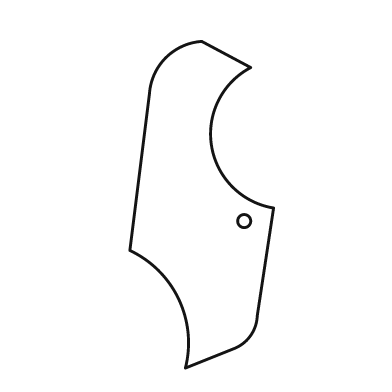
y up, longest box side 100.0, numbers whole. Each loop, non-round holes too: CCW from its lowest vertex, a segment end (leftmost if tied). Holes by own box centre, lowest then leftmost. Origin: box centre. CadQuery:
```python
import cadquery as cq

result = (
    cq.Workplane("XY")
    .moveTo(-5.0, -50.0)
    .lineTo(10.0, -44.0)
    .threePointArc((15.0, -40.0), (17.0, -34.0))
    .lineTo(22.0, -1.0)
    .threePointArc((3.0, 18.0), (15.0, 42.0))
    .lineTo(0.0, 50.0)
    .threePointArc((-11.0, 45.0), (-16.0, 34.0))
    .lineTo(-22.0, -14.0)
    .threePointArc((-7.0, -29.0), (-5.0, -50.0))
    .close()
    .moveTo(13.0, -5.0)
    .circle(2.0)
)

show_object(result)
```